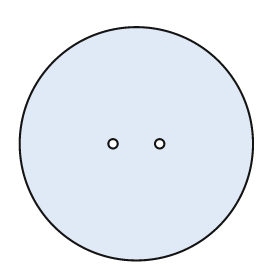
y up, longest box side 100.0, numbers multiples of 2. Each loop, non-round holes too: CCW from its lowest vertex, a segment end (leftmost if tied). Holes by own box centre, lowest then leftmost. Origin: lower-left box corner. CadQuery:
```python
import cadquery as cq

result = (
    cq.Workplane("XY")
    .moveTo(50.0, 50.0)
    .circle(50.0)
    .moveTo(40.0, 50.0)
    .circle(2.0)
    .moveTo(60.0, 50.0)
    .circle(2.0)
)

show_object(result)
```